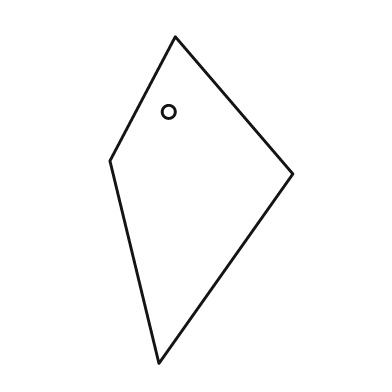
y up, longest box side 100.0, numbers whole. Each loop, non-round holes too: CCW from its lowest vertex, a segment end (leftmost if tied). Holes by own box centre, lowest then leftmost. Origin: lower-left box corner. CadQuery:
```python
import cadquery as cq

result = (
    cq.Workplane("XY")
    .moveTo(15.0, 0.0)
    .lineTo(56.0, 58.0)
    .lineTo(20.0, 100.0)
    .lineTo(0.0, 62.0)
    .close()
    .moveTo(18.0, 77.0)
    .circle(2.0)
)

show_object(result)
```